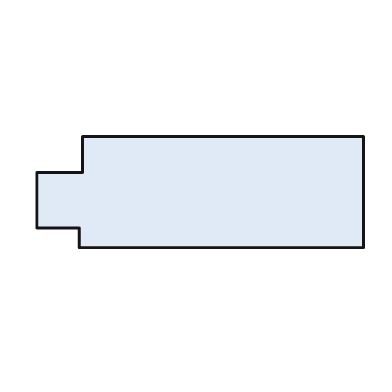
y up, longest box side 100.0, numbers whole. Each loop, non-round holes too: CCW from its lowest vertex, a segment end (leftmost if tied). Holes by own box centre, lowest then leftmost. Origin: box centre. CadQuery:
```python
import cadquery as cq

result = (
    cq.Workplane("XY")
    .moveTo(-37.0, -17.0)
    .lineTo(50.0, -17.0)
    .lineTo(50.0, 17.0)
    .lineTo(-36.0, 17.0)
    .lineTo(-36.0, 6.0)
    .lineTo(-50.0, 6.0)
    .lineTo(-50.0, -11.0)
    .lineTo(-37.0, -11.0)
    .close()
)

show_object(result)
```